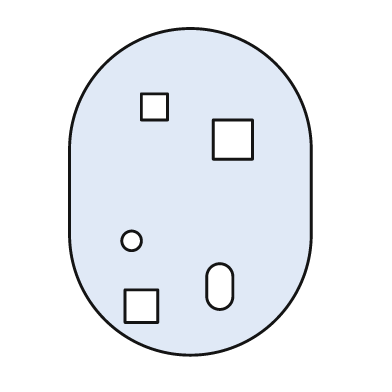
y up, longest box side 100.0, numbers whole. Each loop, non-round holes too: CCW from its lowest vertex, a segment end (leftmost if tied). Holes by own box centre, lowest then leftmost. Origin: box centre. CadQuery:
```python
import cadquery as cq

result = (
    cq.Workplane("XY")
    .moveTo(-37.0, -13.0)
    .threePointArc((0.0, -50.0), (37.0, -13.0))
    .lineTo(37.0, 13.0)
    .threePointArc((0.0, 50.0), (-37.0, 13.0))
    .close()
    .moveTo(-20.0, -40.0)
    .lineTo(-10.0, -40.0)
    .lineTo(-10.0, -30.0)
    .lineTo(-20.0, -30.0)
    .close()
    .moveTo(5.0, -32.0)
    .threePointArc((9.0, -36.0), (13.0, -32.0))
    .lineTo(13.0, -26.0)
    .threePointArc((9.0, -22.0), (5.0, -26.0))
    .close()
    .moveTo(-18.0, -15.0)
    .circle(3.0)
    .moveTo(7.0, 10.0)
    .lineTo(19.0, 10.0)
    .lineTo(19.0, 22.0)
    .lineTo(7.0, 22.0)
    .close()
    .moveTo(-15.0, 22.0)
    .lineTo(-7.0, 22.0)
    .lineTo(-7.0, 30.0)
    .lineTo(-15.0, 30.0)
    .close()
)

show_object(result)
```